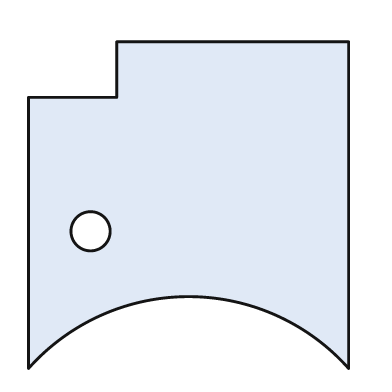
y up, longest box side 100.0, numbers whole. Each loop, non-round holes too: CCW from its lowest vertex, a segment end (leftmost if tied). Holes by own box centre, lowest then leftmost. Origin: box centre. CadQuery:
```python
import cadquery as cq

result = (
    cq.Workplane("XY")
    .moveTo(-49.0, -50.0)
    .threePointArc((0.0, -28.0), (49.0, -50.0))
    .lineTo(49.0, 50.0)
    .lineTo(-22.0, 50.0)
    .lineTo(-22.0, 33.0)
    .lineTo(-49.0, 33.0)
    .close()
    .moveTo(-30.0, -8.0)
    .circle(6.0)
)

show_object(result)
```